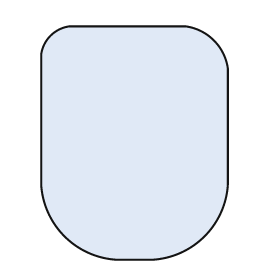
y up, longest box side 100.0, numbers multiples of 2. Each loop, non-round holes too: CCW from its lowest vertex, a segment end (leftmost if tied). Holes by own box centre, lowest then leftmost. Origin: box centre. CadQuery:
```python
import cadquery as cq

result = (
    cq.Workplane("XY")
    .moveTo(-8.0, -50.0)
    .lineTo(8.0, -50.0)
    .threePointArc((30.0, -40.0), (40.0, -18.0))
    .lineTo(40.0, 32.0)
    .threePointArc((34.0, 44.0), (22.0, 50.0))
    .lineTo(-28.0, 50.0)
    .threePointArc((-36.0, 46.0), (-40.0, 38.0))
    .lineTo(-40.0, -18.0)
    .threePointArc((-30.0, -40.0), (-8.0, -50.0))
    .close()
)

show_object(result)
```